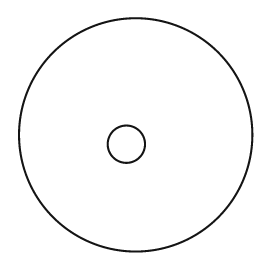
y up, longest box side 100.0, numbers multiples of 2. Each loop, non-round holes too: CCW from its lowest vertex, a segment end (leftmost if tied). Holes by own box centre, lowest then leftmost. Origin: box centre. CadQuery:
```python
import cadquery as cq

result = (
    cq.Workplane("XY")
    .moveTo(0.0, 0.0)
    .circle(50.0)
    .moveTo(-4.0, -4.0)
    .circle(8.0)
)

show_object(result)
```